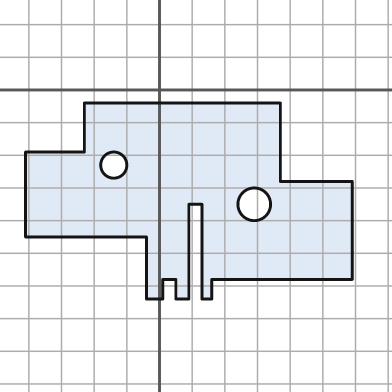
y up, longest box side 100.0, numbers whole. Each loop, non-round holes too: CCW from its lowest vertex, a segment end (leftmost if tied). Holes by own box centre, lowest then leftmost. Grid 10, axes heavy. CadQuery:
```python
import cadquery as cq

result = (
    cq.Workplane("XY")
    .moveTo(-4.0, -64.0)
    .lineTo(1.0, -64.0)
    .lineTo(1.0, -58.0)
    .lineTo(5.0, -58.0)
    .lineTo(5.0, -64.0)
    .lineTo(9.0, -64.0)
    .lineTo(9.0, -35.0)
    .lineTo(13.0, -35.0)
    .lineTo(13.0, -64.0)
    .lineTo(16.0, -64.0)
    .lineTo(16.0, -58.0)
    .lineTo(59.0, -58.0)
    .lineTo(59.0, -28.0)
    .lineTo(37.0, -28.0)
    .lineTo(37.0, -4.0)
    .lineTo(-23.0, -4.0)
    .lineTo(-23.0, -19.0)
    .lineTo(-41.0, -19.0)
    .lineTo(-41.0, -45.0)
    .lineTo(-4.0, -45.0)
    .close()
    .moveTo(29.0, -35.0)
    .circle(5.0)
    .moveTo(-14.0, -23.0)
    .circle(4.0)
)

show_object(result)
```